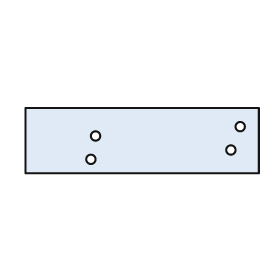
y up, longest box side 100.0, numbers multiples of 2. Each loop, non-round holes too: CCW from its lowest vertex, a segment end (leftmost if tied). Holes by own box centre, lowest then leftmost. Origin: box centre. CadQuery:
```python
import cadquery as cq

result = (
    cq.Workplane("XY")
    .moveTo(-50.0, -14.0)
    .lineTo(50.0, -14.0)
    .lineTo(50.0, 14.0)
    .lineTo(-50.0, 14.0)
    .close()
    .moveTo(-22.0, -8.0)
    .circle(2.0)
    .moveTo(38.0, -4.0)
    .circle(2.0)
    .moveTo(-20.0, 2.0)
    .circle(2.0)
    .moveTo(42.0, 6.0)
    .circle(2.0)
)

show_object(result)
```